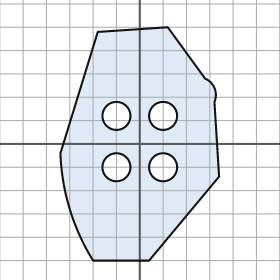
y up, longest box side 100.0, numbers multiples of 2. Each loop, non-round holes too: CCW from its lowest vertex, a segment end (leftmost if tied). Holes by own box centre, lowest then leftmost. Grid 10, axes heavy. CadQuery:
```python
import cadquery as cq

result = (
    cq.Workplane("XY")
    .moveTo(-20.0, -50.0)
    .lineTo(4.0, -50.0)
    .lineTo(34.0, -14.0)
    .lineTo(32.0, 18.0)
    .threePointArc((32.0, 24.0), (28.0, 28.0))
    .lineTo(12.0, 50.0)
    .lineTo(-18.0, 48.0)
    .lineTo(-34.0, -4.0)
    .threePointArc((-30.0, -28.0), (-20.0, -50.0))
    .close()
    .moveTo(-10.0, -10.0)
    .circle(6.0)
    .moveTo(10.0, -10.0)
    .circle(6.0)
    .moveTo(-10.0, 12.0)
    .circle(6.0)
    .moveTo(10.0, 12.0)
    .circle(6.0)
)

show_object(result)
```